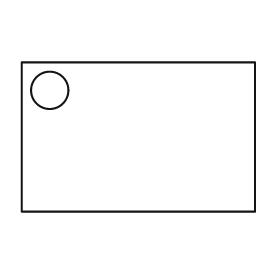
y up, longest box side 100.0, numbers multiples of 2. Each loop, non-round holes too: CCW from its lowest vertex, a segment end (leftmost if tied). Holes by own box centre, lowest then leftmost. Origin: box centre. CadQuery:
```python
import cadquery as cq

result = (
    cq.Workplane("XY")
    .moveTo(-50.0, -32.0)
    .lineTo(50.0, -32.0)
    .lineTo(50.0, 32.0)
    .lineTo(-50.0, 32.0)
    .close()
    .moveTo(-38.0, 20.0)
    .circle(8.0)
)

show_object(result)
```